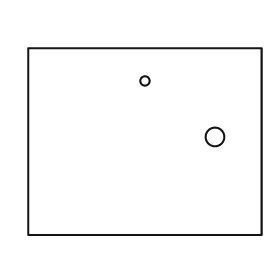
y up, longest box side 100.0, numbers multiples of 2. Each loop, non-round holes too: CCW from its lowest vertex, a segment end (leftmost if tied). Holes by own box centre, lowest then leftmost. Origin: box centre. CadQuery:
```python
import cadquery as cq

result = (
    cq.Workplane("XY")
    .moveTo(-50.0, -40.0)
    .lineTo(50.0, -40.0)
    .lineTo(50.0, 40.0)
    .lineTo(-50.0, 40.0)
    .close()
    .moveTo(30.0, 2.0)
    .circle(4.0)
    .moveTo(0.0, 26.0)
    .circle(2.0)
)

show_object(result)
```